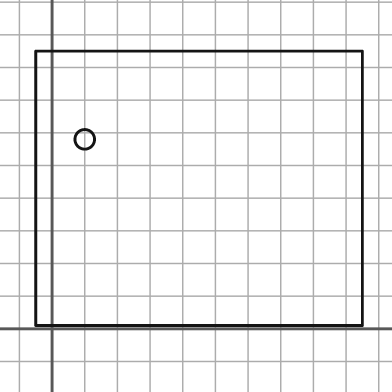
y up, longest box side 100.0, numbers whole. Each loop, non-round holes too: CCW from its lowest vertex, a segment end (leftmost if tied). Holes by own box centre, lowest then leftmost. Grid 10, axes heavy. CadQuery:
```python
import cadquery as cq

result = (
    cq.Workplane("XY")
    .moveTo(-5.0, 1.0)
    .lineTo(95.0, 1.0)
    .lineTo(95.0, 85.0)
    .lineTo(-5.0, 85.0)
    .close()
    .moveTo(10.0, 58.0)
    .circle(3.0)
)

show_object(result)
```